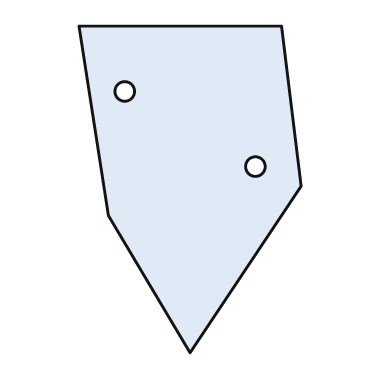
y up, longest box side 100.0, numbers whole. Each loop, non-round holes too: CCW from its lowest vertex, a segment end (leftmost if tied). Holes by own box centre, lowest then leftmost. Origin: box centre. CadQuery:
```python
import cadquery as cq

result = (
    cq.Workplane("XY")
    .moveTo(0.0, -50.0)
    .lineTo(34.0, 1.0)
    .lineTo(28.0, 50.0)
    .lineTo(-34.0, 50.0)
    .lineTo(-25.0, -8.0)
    .close()
    .moveTo(20.0, 7.0)
    .circle(3.0)
    .moveTo(-20.0, 30.0)
    .circle(3.0)
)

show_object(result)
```